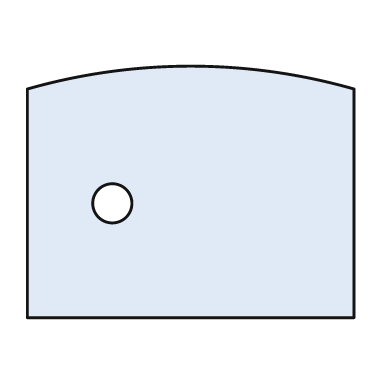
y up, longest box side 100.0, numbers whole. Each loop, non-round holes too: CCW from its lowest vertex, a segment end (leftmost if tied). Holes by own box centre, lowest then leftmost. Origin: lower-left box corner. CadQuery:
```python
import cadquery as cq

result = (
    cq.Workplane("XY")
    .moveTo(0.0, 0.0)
    .lineTo(100.0, 0.0)
    .lineTo(100.0, 70.0)
    .threePointArc((50.0, 77.0), (0.0, 70.0))
    .close()
    .moveTo(26.0, 35.0)
    .circle(6.0)
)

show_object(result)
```